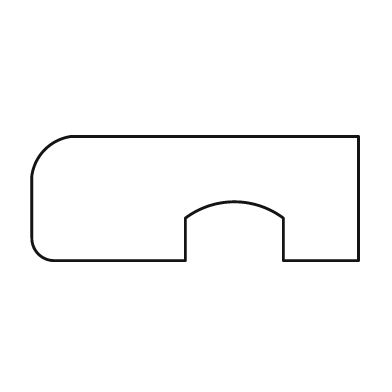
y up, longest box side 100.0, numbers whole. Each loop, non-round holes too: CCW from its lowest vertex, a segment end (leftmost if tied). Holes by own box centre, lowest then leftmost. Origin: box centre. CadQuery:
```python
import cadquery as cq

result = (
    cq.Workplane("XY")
    .moveTo(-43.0, -19.0)
    .lineTo(-3.0, -19.0)
    .lineTo(-3.0, -6.0)
    .threePointArc((12.0, -1.0), (27.0, -6.0))
    .lineTo(27.0, -19.0)
    .lineTo(50.0, -19.0)
    .lineTo(50.0, 19.0)
    .lineTo(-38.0, 19.0)
    .threePointArc((-46.0, 15.0), (-50.0, 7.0))
    .lineTo(-50.0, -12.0)
    .threePointArc((-48.0, -17.0), (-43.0, -19.0))
    .close()
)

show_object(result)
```